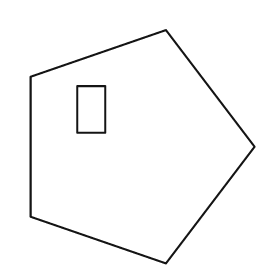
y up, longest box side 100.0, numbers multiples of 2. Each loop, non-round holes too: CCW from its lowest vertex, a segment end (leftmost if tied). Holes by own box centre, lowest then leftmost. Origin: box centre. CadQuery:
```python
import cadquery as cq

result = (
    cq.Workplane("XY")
    .moveTo(10.0, -50.0)
    .lineTo(48.0, 0.0)
    .lineTo(10.0, 50.0)
    .lineTo(-48.0, 30.0)
    .lineTo(-48.0, -30.0)
    .close()
    .moveTo(-28.0, 6.0)
    .lineTo(-16.0, 6.0)
    .lineTo(-16.0, 26.0)
    .lineTo(-28.0, 26.0)
    .close()
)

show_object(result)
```